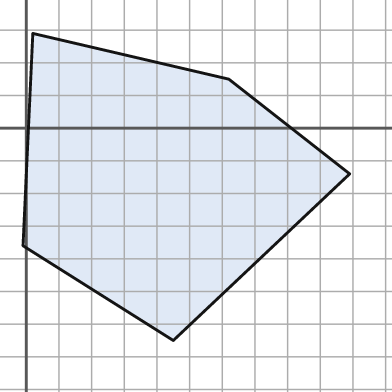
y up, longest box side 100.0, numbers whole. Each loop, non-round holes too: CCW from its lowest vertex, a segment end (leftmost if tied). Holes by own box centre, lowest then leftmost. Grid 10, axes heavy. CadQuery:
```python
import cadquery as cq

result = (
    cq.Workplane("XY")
    .moveTo(45.0, -65.0)
    .lineTo(99.0, -14.0)
    .lineTo(62.0, 15.0)
    .lineTo(2.0, 29.0)
    .lineTo(-1.0, -36.0)
    .close()
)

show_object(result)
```